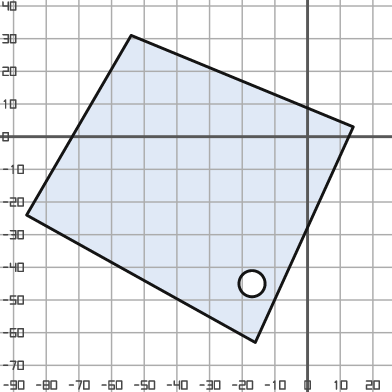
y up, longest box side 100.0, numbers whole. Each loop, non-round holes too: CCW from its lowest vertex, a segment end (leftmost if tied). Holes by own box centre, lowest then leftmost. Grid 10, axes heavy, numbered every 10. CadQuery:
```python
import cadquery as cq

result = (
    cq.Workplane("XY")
    .moveTo(-16.0, -63.0)
    .lineTo(14.0, 3.0)
    .lineTo(-54.0, 31.0)
    .lineTo(-86.0, -24.0)
    .close()
    .moveTo(-17.0, -45.0)
    .circle(4.0)
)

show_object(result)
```